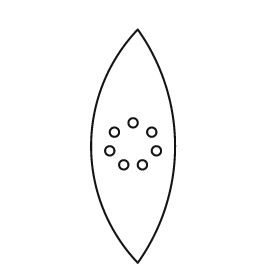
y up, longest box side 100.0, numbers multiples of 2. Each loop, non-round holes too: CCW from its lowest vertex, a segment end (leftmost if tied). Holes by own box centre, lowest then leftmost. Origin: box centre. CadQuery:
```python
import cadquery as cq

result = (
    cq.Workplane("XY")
    .moveTo(2.0, -50.0)
    .threePointArc((18.0, 0.0), (2.0, 50.0))
    .threePointArc((-18.0, 0.0), (2.0, -50.0))
    .close()
    .moveTo(-4.0, -8.0)
    .circle(2.0)
    .moveTo(4.0, -8.0)
    .circle(2.0)
    .moveTo(-10.0, -2.0)
    .circle(2.0)
    .moveTo(10.0, -2.0)
    .circle(2.0)
    .moveTo(-8.0, 6.0)
    .circle(2.0)
    .moveTo(8.0, 6.0)
    .circle(2.0)
    .moveTo(0.0, 10.0)
    .circle(2.0)
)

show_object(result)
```